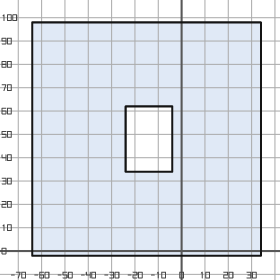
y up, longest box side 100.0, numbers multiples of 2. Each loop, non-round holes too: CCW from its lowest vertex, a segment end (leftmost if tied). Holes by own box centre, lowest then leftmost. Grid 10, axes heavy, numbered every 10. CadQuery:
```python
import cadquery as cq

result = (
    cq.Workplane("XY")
    .moveTo(-64.0, -2.0)
    .lineTo(34.0, -2.0)
    .lineTo(34.0, 98.0)
    .lineTo(-64.0, 98.0)
    .close()
    .moveTo(-24.0, 34.0)
    .lineTo(-4.0, 34.0)
    .lineTo(-4.0, 62.0)
    .lineTo(-24.0, 62.0)
    .close()
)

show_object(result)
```